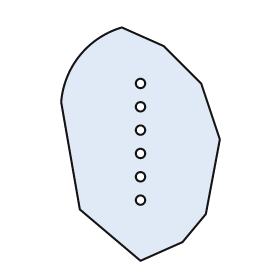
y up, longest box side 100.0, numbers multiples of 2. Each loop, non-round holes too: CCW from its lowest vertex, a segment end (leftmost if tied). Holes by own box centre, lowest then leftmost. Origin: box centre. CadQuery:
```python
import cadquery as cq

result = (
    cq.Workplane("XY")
    .moveTo(0.0, -50.0)
    .lineTo(18.0, -42.0)
    .lineTo(28.0, -30.0)
    .lineTo(34.0, 2.0)
    .lineTo(26.0, 26.0)
    .lineTo(10.0, 42.0)
    .lineTo(-8.0, 50.0)
    .threePointArc((-26.0, 38.0), (-34.0, 18.0))
    .lineTo(-26.0, -28.0)
    .close()
    .moveTo(0.0, -24.0)
    .circle(2.0)
    .moveTo(0.0, -14.0)
    .circle(2.0)
    .moveTo(0.0, -4.0)
    .circle(2.0)
    .moveTo(0.0, 6.0)
    .circle(2.0)
    .moveTo(0.0, 16.0)
    .circle(2.0)
    .moveTo(0.0, 26.0)
    .circle(2.0)
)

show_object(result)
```